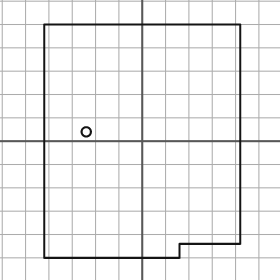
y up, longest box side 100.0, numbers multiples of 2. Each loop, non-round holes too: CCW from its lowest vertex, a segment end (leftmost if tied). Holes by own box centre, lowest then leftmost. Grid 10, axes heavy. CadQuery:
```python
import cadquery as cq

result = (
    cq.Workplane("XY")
    .moveTo(-42.0, -50.0)
    .lineTo(16.0, -50.0)
    .lineTo(16.0, -44.0)
    .lineTo(42.0, -44.0)
    .lineTo(42.0, 50.0)
    .lineTo(-42.0, 50.0)
    .close()
    .moveTo(-24.0, 4.0)
    .circle(2.0)
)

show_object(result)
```